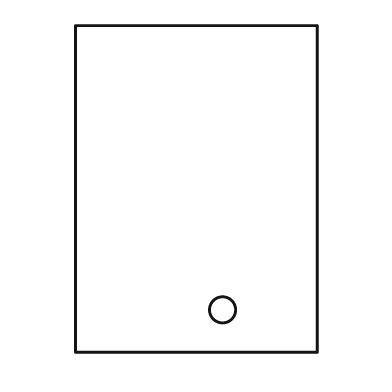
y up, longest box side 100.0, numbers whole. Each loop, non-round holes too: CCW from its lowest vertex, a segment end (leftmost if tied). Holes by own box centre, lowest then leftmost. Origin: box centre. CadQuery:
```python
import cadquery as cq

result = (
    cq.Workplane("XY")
    .moveTo(-37.0, -50.0)
    .lineTo(37.0, -50.0)
    .lineTo(37.0, 50.0)
    .lineTo(-37.0, 50.0)
    .close()
    .moveTo(8.0, -37.0)
    .circle(4.0)
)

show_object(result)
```